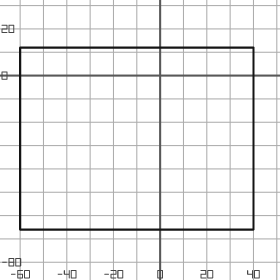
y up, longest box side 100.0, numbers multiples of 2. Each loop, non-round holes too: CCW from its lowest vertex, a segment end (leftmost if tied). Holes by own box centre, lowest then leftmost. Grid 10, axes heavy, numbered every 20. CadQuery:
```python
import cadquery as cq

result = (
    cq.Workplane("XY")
    .moveTo(-60.0, -66.0)
    .lineTo(40.0, -66.0)
    .lineTo(40.0, 12.0)
    .lineTo(-60.0, 12.0)
    .close()
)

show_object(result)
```